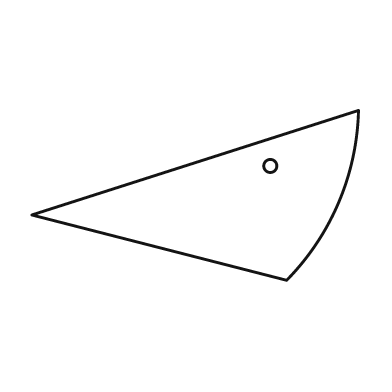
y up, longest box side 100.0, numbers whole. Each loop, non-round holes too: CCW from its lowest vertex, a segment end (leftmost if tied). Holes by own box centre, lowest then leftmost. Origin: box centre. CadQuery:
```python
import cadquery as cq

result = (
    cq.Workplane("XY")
    .moveTo(28.0, -26.0)
    .threePointArc((44.0, -2.0), (50.0, 26.0))
    .lineTo(-50.0, -6.0)
    .close()
    .moveTo(23.0, 9.0)
    .circle(2.0)
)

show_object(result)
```